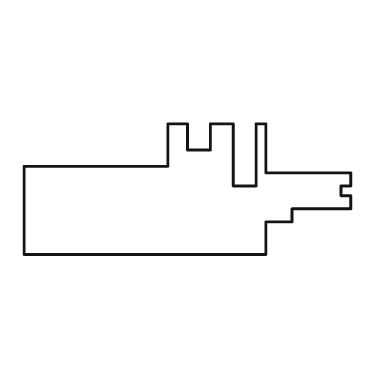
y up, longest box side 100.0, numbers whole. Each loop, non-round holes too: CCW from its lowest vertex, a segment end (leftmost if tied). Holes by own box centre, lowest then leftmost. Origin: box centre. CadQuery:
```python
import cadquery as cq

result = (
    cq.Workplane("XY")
    .moveTo(-50.0, -20.0)
    .lineTo(24.0, -20.0)
    .lineTo(24.0, -10.0)
    .lineTo(32.0, -10.0)
    .lineTo(32.0, -6.0)
    .lineTo(50.0, -6.0)
    .lineTo(50.0, -2.0)
    .lineTo(47.0, -2.0)
    .lineTo(47.0, 1.0)
    .lineTo(50.0, 1.0)
    .lineTo(50.0, 5.0)
    .lineTo(24.0, 5.0)
    .lineTo(24.0, 20.0)
    .lineTo(21.0, 20.0)
    .lineTo(21.0, 1.0)
    .lineTo(14.0, 1.0)
    .lineTo(14.0, 20.0)
    .lineTo(7.0, 20.0)
    .lineTo(7.0, 12.0)
    .lineTo(0.0, 12.0)
    .lineTo(0.0, 20.0)
    .lineTo(-6.0, 20.0)
    .lineTo(-6.0, 7.0)
    .lineTo(-50.0, 7.0)
    .close()
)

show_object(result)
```